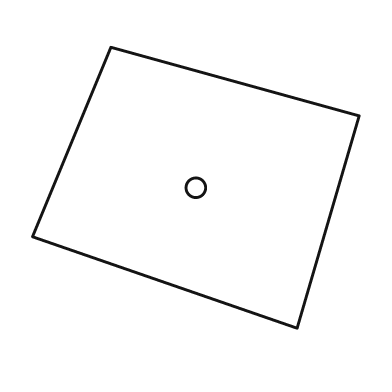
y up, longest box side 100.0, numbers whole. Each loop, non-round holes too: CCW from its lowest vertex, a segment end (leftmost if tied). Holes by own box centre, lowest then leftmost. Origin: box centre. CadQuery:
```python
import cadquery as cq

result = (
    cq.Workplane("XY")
    .moveTo(31.0, -43.0)
    .lineTo(50.0, 22.0)
    .lineTo(-26.0, 43.0)
    .lineTo(-50.0, -15.0)
    .close()
    .moveTo(0.0, 0.0)
    .circle(3.0)
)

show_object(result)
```